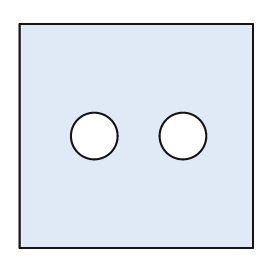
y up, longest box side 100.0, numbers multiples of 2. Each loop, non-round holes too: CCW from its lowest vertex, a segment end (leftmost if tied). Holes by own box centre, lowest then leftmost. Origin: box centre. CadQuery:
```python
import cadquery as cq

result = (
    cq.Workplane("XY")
    .moveTo(-50.0, -48.0)
    .lineTo(50.0, -48.0)
    .lineTo(50.0, 48.0)
    .lineTo(-50.0, 48.0)
    .close()
    .moveTo(-18.0, 0.0)
    .circle(10.0)
    .moveTo(20.0, 0.0)
    .circle(10.0)
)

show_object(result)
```